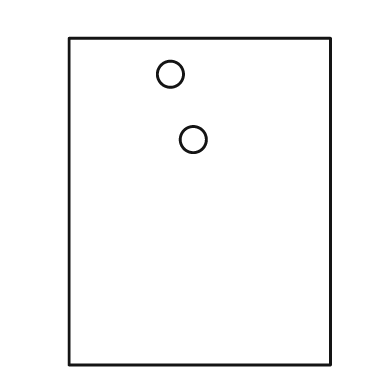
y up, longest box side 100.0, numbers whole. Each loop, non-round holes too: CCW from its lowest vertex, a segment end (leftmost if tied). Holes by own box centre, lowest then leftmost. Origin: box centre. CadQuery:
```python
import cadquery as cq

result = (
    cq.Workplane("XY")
    .moveTo(-40.0, -50.0)
    .lineTo(40.0, -50.0)
    .lineTo(40.0, 50.0)
    .lineTo(-40.0, 50.0)
    .close()
    .moveTo(-2.0, 19.0)
    .circle(4.0)
    .moveTo(-9.0, 39.0)
    .circle(4.0)
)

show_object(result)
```